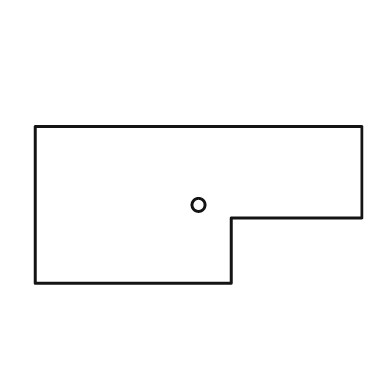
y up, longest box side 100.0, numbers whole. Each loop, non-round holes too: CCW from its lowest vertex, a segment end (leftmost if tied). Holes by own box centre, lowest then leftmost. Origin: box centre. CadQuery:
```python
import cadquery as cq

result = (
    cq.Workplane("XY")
    .moveTo(-50.0, -24.0)
    .lineTo(10.0, -24.0)
    .lineTo(10.0, -4.0)
    .lineTo(50.0, -4.0)
    .lineTo(50.0, 24.0)
    .lineTo(-50.0, 24.0)
    .close()
    .moveTo(0.0, 0.0)
    .circle(2.0)
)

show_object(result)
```